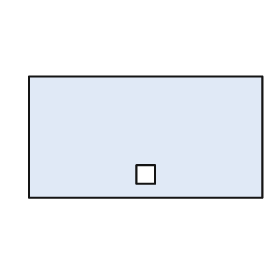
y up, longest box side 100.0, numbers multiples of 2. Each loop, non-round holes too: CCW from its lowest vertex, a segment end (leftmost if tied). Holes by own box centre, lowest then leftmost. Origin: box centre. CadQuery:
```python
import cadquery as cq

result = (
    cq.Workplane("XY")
    .moveTo(-50.0, -26.0)
    .lineTo(50.0, -26.0)
    .lineTo(50.0, 26.0)
    .lineTo(-50.0, 26.0)
    .close()
    .moveTo(-4.0, -20.0)
    .lineTo(4.0, -20.0)
    .lineTo(4.0, -12.0)
    .lineTo(-4.0, -12.0)
    .close()
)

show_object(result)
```